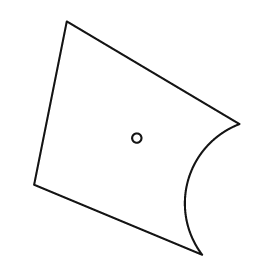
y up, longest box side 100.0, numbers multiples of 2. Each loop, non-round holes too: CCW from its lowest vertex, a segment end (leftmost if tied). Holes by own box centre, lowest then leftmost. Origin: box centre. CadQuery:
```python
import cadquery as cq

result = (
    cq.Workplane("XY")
    .moveTo(28.0, -50.0)
    .threePointArc((22.0, -18.0), (44.0, 6.0))
    .lineTo(-30.0, 50.0)
    .lineTo(-44.0, -20.0)
    .close()
    .moveTo(0.0, 0.0)
    .circle(2.0)
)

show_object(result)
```